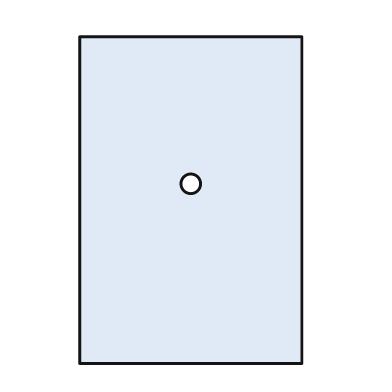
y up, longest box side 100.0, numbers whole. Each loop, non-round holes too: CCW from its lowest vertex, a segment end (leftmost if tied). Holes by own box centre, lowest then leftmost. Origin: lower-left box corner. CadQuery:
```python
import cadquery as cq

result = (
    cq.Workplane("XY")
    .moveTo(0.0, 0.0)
    .lineTo(68.0, 0.0)
    .lineTo(68.0, 100.0)
    .lineTo(0.0, 100.0)
    .close()
    .moveTo(34.0, 55.0)
    .circle(3.0)
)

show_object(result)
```